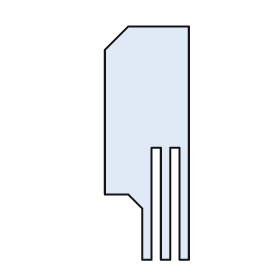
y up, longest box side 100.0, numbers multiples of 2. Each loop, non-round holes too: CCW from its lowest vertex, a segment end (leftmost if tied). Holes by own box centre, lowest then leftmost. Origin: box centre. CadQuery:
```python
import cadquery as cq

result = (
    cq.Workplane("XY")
    .moveTo(-2.0, -50.0)
    .lineTo(2.0, -50.0)
    .lineTo(2.0, -2.0)
    .lineTo(6.0, -2.0)
    .lineTo(6.0, -50.0)
    .lineTo(10.0, -50.0)
    .lineTo(10.0, -2.0)
    .lineTo(14.0, -2.0)
    .lineTo(14.0, -50.0)
    .lineTo(18.0, -50.0)
    .lineTo(18.0, 50.0)
    .lineTo(-8.0, 50.0)
    .lineTo(-18.0, 40.0)
    .lineTo(-18.0, -22.0)
    .lineTo(-8.0, -22.0)
    .lineTo(-2.0, -28.0)
    .close()
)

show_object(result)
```